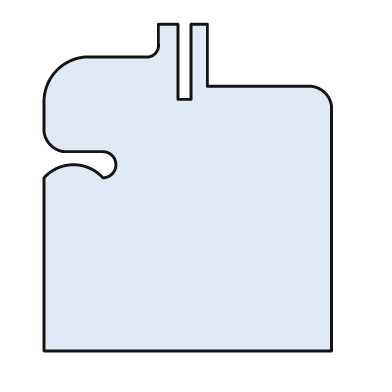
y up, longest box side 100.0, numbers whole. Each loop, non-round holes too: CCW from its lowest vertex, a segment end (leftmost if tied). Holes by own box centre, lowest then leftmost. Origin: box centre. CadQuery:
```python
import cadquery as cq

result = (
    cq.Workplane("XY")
    .moveTo(-44.0, -50.0)
    .lineTo(44.0, -50.0)
    .lineTo(44.0, 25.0)
    .threePointArc((42.0, 29.0), (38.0, 31.0))
    .lineTo(6.0, 31.0)
    .lineTo(6.0, 50.0)
    .lineTo(1.0, 50.0)
    .lineTo(1.0, 27.0)
    .lineTo(-3.0, 27.0)
    .lineTo(-3.0, 50.0)
    .lineTo(-9.0, 50.0)
    .lineTo(-9.0, 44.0)
    .threePointArc((-10.0, 41.0), (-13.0, 40.0))
    .lineTo(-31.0, 40.0)
    .threePointArc((-40.0, 36.0), (-44.0, 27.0))
    .lineTo(-44.0, 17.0)
    .threePointArc((-42.0, 13.0), (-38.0, 11.0))
    .lineTo(-26.0, 11.0)
    .threePointArc((-22.0, 7.0), (-26.0, 3.0))
    .threePointArc((-35.0, 7.0), (-44.0, 3.0))
    .close()
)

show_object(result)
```